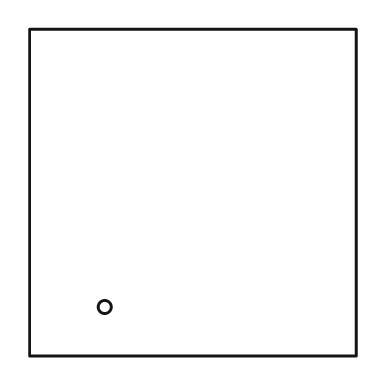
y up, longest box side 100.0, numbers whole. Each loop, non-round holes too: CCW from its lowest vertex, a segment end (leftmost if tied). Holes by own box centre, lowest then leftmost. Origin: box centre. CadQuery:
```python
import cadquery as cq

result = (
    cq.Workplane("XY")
    .moveTo(-50.0, -50.0)
    .lineTo(50.0, -50.0)
    .lineTo(50.0, 50.0)
    .lineTo(-50.0, 50.0)
    .close()
    .moveTo(-27.0, -35.0)
    .circle(2.0)
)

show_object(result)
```